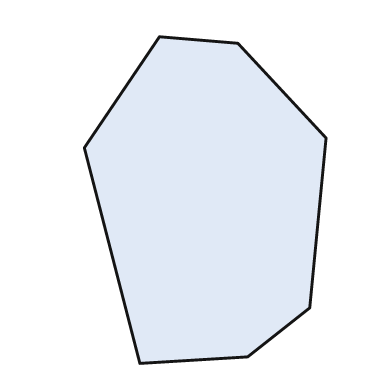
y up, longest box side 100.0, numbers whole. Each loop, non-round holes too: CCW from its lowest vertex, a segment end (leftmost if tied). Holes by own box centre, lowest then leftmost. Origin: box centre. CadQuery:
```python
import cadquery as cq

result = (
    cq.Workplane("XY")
    .moveTo(-20.0, -50.0)
    .lineTo(13.0, -48.0)
    .lineTo(32.0, -33.0)
    .lineTo(37.0, 19.0)
    .lineTo(10.0, 48.0)
    .lineTo(-14.0, 50.0)
    .lineTo(-37.0, 16.0)
    .close()
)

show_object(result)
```